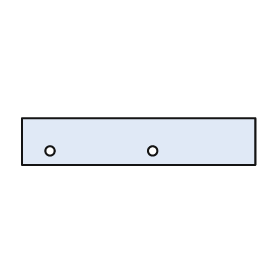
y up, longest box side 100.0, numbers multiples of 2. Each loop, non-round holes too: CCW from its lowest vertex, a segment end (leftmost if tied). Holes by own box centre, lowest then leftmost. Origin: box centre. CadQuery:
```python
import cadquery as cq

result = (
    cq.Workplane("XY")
    .moveTo(-50.0, -10.0)
    .lineTo(50.0, -10.0)
    .lineTo(50.0, 10.0)
    .lineTo(-50.0, 10.0)
    .close()
    .moveTo(-38.0, -4.0)
    .circle(2.0)
    .moveTo(6.0, -4.0)
    .circle(2.0)
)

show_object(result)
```